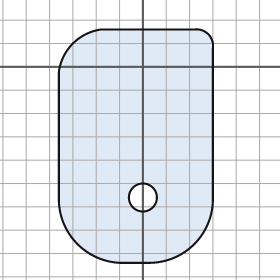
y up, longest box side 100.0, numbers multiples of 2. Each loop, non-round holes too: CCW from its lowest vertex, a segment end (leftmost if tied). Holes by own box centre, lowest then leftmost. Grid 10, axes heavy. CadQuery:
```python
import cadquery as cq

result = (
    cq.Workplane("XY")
    .moveTo(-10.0, -84.0)
    .lineTo(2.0, -84.0)
    .threePointArc((22.0, -76.0), (30.0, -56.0))
    .lineTo(30.0, 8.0)
    .threePointArc((28.0, 14.0), (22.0, 16.0))
    .lineTo(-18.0, 16.0)
    .threePointArc((-30.0, 10.0), (-36.0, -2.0))
    .lineTo(-36.0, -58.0)
    .threePointArc((-28.0, -76.0), (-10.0, -84.0))
    .close()
    .moveTo(0.0, -56.0)
    .circle(6.0)
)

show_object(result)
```